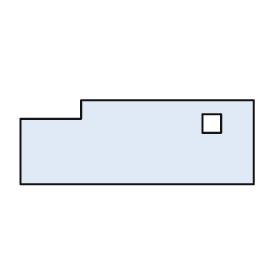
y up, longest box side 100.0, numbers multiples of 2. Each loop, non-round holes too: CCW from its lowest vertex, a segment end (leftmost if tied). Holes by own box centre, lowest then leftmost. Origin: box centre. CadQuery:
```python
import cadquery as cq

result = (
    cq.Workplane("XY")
    .moveTo(-50.0, -18.0)
    .lineTo(50.0, -18.0)
    .lineTo(50.0, 18.0)
    .lineTo(-24.0, 18.0)
    .lineTo(-24.0, 10.0)
    .lineTo(-50.0, 10.0)
    .close()
    .moveTo(28.0, 4.0)
    .lineTo(36.0, 4.0)
    .lineTo(36.0, 12.0)
    .lineTo(28.0, 12.0)
    .close()
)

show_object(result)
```